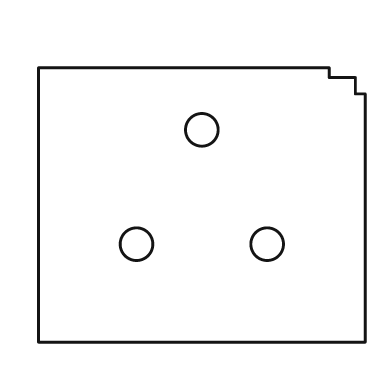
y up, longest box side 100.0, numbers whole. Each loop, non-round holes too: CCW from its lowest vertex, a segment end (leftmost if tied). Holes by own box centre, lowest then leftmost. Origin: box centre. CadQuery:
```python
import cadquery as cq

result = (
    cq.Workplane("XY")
    .moveTo(-50.0, -42.0)
    .lineTo(50.0, -42.0)
    .lineTo(50.0, 34.0)
    .lineTo(47.0, 34.0)
    .lineTo(47.0, 39.0)
    .lineTo(39.0, 39.0)
    .lineTo(39.0, 42.0)
    .lineTo(-50.0, 42.0)
    .close()
    .moveTo(-20.0, -12.0)
    .circle(5.0)
    .moveTo(20.0, -12.0)
    .circle(5.0)
    .moveTo(0.0, 23.0)
    .circle(5.0)
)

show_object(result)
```